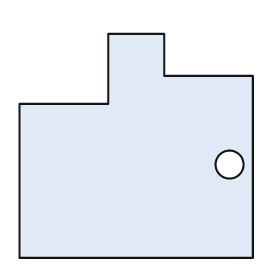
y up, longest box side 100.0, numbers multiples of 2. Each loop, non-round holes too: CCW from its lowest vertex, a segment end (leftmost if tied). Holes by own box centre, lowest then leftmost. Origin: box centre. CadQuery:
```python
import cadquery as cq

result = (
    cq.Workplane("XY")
    .moveTo(-50.0, -48.0)
    .lineTo(50.0, -48.0)
    .lineTo(50.0, 30.0)
    .lineTo(12.0, 30.0)
    .lineTo(12.0, 48.0)
    .lineTo(-12.0, 48.0)
    .lineTo(-12.0, 18.0)
    .lineTo(-50.0, 18.0)
    .close()
    .moveTo(40.0, -8.0)
    .circle(6.0)
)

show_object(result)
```